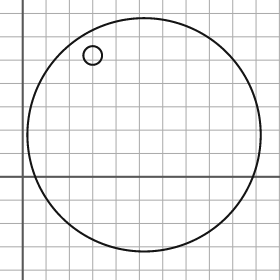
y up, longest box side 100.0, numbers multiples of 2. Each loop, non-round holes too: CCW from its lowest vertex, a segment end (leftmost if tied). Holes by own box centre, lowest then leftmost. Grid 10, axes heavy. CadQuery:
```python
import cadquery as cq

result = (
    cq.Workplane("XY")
    .moveTo(52.0, 18.0)
    .circle(50.0)
    .moveTo(30.0, 52.0)
    .circle(4.0)
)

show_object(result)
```